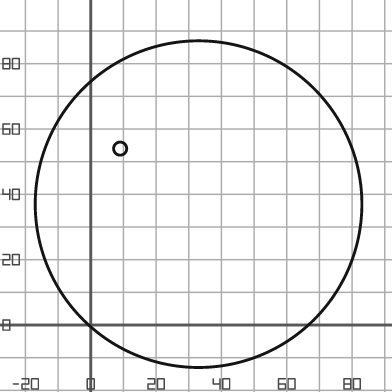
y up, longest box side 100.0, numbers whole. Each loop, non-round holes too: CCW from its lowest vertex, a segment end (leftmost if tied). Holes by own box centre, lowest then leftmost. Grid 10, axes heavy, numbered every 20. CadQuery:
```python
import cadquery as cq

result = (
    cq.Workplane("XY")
    .moveTo(33.0, 37.0)
    .circle(50.0)
    .moveTo(9.0, 54.0)
    .circle(2.0)
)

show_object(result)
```